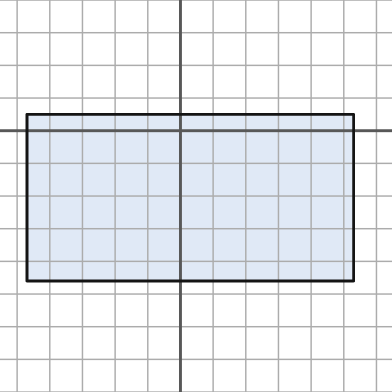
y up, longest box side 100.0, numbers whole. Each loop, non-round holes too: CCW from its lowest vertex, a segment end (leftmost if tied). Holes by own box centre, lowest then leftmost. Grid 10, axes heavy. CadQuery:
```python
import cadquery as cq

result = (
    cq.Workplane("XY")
    .moveTo(-47.0, -46.0)
    .lineTo(53.0, -46.0)
    .lineTo(53.0, 5.0)
    .lineTo(-47.0, 5.0)
    .close()
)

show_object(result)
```